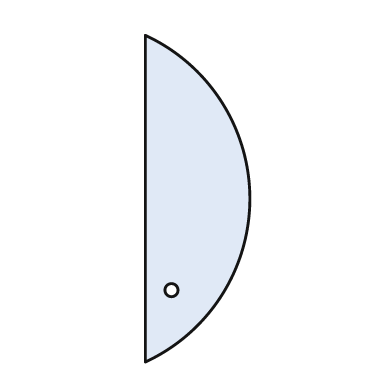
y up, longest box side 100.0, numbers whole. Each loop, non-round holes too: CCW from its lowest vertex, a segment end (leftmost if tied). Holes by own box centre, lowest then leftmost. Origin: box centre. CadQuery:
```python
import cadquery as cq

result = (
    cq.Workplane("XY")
    .moveTo(-16.0, -50.0)
    .threePointArc((16.0, 0.0), (-16.0, 50.0))
    .close()
    .moveTo(-8.0, -28.0)
    .circle(2.0)
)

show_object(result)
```